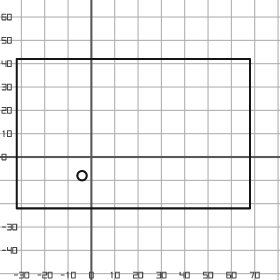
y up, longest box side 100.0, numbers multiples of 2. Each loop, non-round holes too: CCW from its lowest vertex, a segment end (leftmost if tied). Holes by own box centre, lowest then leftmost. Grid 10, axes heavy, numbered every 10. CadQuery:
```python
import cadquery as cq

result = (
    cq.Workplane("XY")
    .moveTo(-32.0, -22.0)
    .lineTo(68.0, -22.0)
    .lineTo(68.0, 42.0)
    .lineTo(-32.0, 42.0)
    .close()
    .moveTo(-4.0, -8.0)
    .circle(2.0)
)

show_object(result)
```